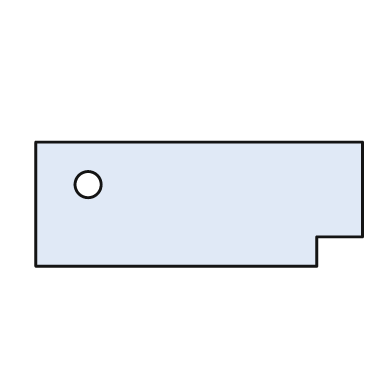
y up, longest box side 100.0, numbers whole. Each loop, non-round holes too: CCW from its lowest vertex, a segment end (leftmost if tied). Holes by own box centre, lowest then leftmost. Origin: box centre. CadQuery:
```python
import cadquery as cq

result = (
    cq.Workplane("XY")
    .moveTo(-50.0, -19.0)
    .lineTo(36.0, -19.0)
    .lineTo(36.0, -10.0)
    .lineTo(50.0, -10.0)
    .lineTo(50.0, 19.0)
    .lineTo(-50.0, 19.0)
    .close()
    .moveTo(-34.0, 6.0)
    .circle(4.0)
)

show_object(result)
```